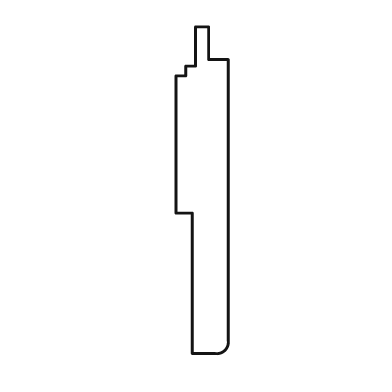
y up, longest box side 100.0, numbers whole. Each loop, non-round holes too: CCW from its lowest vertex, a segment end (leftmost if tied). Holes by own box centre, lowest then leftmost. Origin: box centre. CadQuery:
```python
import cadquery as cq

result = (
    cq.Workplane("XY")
    .moveTo(-3.0, -50.0)
    .lineTo(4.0, -50.0)
    .threePointArc((7.0, -49.0), (8.0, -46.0))
    .lineTo(8.0, 40.0)
    .lineTo(2.0, 40.0)
    .lineTo(2.0, 50.0)
    .lineTo(-2.0, 50.0)
    .lineTo(-2.0, 38.0)
    .lineTo(-5.0, 38.0)
    .lineTo(-5.0, 35.0)
    .lineTo(-8.0, 35.0)
    .lineTo(-8.0, -7.0)
    .lineTo(-3.0, -7.0)
    .close()
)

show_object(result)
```